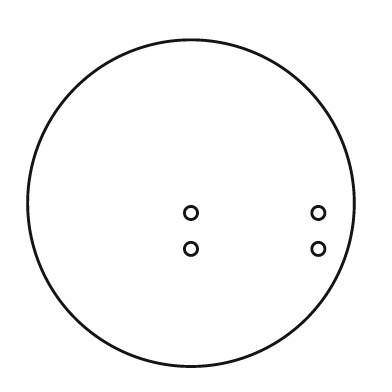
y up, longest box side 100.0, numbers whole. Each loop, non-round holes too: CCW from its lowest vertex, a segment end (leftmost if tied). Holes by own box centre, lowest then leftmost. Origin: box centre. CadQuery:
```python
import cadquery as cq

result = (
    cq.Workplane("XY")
    .moveTo(0.0, 0.0)
    .circle(50.0)
    .moveTo(0.0, -14.0)
    .circle(2.0)
    .moveTo(39.0, -14.0)
    .circle(2.0)
    .moveTo(0.0, -3.0)
    .circle(2.0)
    .moveTo(39.0, -3.0)
    .circle(2.0)
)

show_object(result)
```